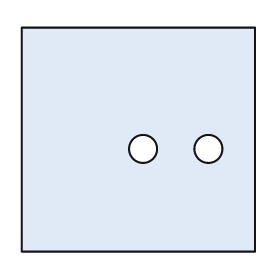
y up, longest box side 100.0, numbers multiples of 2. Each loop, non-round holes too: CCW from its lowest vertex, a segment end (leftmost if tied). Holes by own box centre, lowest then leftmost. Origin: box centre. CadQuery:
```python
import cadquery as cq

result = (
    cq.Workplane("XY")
    .moveTo(-50.0, -48.0)
    .lineTo(50.0, -48.0)
    .lineTo(50.0, 48.0)
    .lineTo(-50.0, 48.0)
    .close()
    .moveTo(2.0, -4.0)
    .circle(6.0)
    .moveTo(30.0, -4.0)
    .circle(6.0)
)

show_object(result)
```